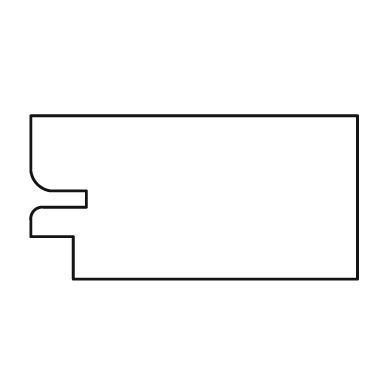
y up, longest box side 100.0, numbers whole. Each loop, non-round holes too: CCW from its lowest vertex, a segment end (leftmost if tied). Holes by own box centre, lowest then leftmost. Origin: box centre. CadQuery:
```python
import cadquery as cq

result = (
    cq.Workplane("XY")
    .moveTo(-37.0, -25.0)
    .lineTo(50.0, -25.0)
    .lineTo(50.0, 25.0)
    .lineTo(-50.0, 25.0)
    .lineTo(-50.0, 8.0)
    .threePointArc((-48.0, 4.0), (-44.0, 2.0))
    .lineTo(-33.0, 2.0)
    .lineTo(-33.0, -3.0)
    .lineTo(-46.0, -3.0)
    .threePointArc((-49.0, -4.0), (-50.0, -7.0))
    .lineTo(-50.0, -12.0)
    .lineTo(-37.0, -12.0)
    .close()
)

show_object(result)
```